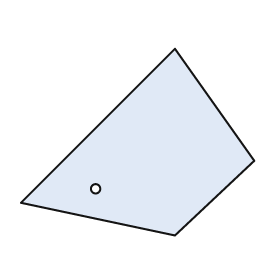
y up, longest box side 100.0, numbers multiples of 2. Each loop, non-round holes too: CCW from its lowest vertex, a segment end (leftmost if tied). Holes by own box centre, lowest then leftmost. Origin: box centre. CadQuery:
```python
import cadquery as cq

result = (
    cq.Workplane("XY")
    .moveTo(16.0, -40.0)
    .lineTo(50.0, -8.0)
    .lineTo(16.0, 40.0)
    .lineTo(-50.0, -26.0)
    .close()
    .moveTo(-18.0, -20.0)
    .circle(2.0)
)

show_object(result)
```